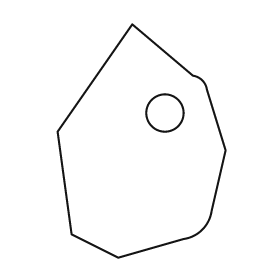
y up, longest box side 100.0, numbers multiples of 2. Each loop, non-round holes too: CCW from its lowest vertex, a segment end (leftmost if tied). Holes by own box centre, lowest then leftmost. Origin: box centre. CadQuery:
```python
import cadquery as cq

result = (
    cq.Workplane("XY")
    .moveTo(-10.0, -50.0)
    .lineTo(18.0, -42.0)
    .threePointArc((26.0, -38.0), (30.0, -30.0))
    .lineTo(36.0, -4.0)
    .lineTo(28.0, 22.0)
    .threePointArc((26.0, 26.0), (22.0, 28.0))
    .lineTo(-4.0, 50.0)
    .lineTo(-36.0, 4.0)
    .lineTo(-30.0, -40.0)
    .close()
    .moveTo(10.0, 12.0)
    .circle(8.0)
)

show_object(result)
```